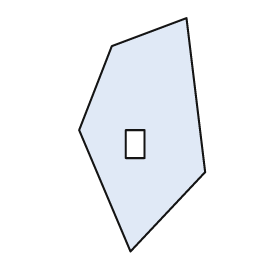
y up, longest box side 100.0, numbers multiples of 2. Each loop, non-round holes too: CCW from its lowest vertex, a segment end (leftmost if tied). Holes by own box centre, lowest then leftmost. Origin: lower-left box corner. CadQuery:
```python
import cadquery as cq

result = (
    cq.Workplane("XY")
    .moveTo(22.0, 0.0)
    .lineTo(54.0, 34.0)
    .lineTo(46.0, 100.0)
    .lineTo(14.0, 88.0)
    .lineTo(0.0, 52.0)
    .close()
    .moveTo(20.0, 40.0)
    .lineTo(28.0, 40.0)
    .lineTo(28.0, 52.0)
    .lineTo(20.0, 52.0)
    .close()
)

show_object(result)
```